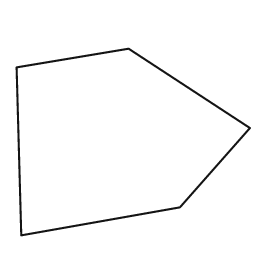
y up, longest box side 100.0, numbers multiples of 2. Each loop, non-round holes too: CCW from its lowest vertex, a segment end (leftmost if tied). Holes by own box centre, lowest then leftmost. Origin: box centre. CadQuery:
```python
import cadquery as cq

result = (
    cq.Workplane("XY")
    .moveTo(-48.0, -40.0)
    .lineTo(20.0, -28.0)
    .lineTo(50.0, 6.0)
    .lineTo(-2.0, 40.0)
    .lineTo(-50.0, 32.0)
    .close()
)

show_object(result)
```